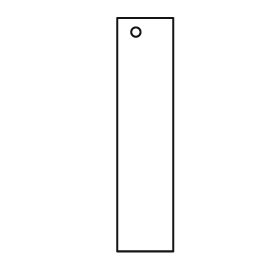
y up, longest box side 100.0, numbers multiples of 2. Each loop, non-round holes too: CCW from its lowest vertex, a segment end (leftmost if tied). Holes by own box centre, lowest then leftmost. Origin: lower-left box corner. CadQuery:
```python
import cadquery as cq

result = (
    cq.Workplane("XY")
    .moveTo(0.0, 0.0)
    .lineTo(24.0, 0.0)
    .lineTo(24.0, 100.0)
    .lineTo(0.0, 100.0)
    .close()
    .moveTo(8.0, 94.0)
    .circle(2.0)
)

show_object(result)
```